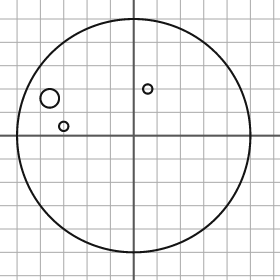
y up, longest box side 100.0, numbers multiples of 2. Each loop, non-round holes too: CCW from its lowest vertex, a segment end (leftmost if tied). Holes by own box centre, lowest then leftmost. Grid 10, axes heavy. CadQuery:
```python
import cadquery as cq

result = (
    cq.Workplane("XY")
    .moveTo(0.0, 0.0)
    .circle(50.0)
    .moveTo(-30.0, 4.0)
    .circle(2.0)
    .moveTo(-36.0, 16.0)
    .circle(4.0)
    .moveTo(6.0, 20.0)
    .circle(2.0)
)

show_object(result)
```